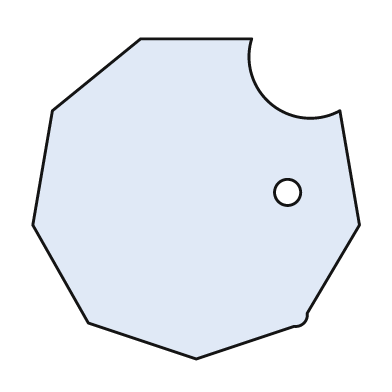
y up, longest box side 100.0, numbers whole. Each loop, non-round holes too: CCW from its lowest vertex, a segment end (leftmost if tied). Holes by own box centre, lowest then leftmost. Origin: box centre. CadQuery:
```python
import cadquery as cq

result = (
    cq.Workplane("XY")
    .moveTo(0.0, -49.0)
    .lineTo(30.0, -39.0)
    .threePointArc((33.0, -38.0), (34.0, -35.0))
    .lineTo(50.0, -8.0)
    .lineTo(44.0, 27.0)
    .threePointArc((23.0, 29.0), (17.0, 49.0))
    .lineTo(-17.0, 49.0)
    .lineTo(-44.0, 27.0)
    .lineTo(-50.0, -8.0)
    .lineTo(-33.0, -38.0)
    .close()
    .moveTo(28.0, 2.0)
    .circle(4.0)
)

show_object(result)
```